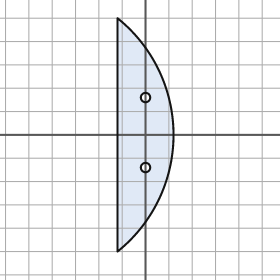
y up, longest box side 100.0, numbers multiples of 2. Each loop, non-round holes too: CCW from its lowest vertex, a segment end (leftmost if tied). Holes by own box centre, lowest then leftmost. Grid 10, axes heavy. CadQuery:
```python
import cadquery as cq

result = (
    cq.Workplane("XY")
    .moveTo(-12.0, -50.0)
    .threePointArc((12.0, 0.0), (-12.0, 50.0))
    .close()
    .moveTo(0.0, -14.0)
    .circle(2.0)
    .moveTo(0.0, 16.0)
    .circle(2.0)
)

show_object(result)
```